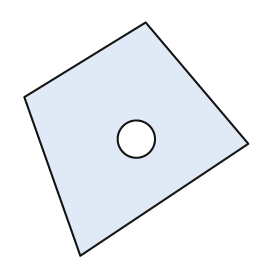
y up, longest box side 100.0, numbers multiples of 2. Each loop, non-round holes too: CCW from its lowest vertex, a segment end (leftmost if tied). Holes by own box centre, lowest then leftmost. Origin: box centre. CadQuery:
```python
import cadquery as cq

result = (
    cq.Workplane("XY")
    .moveTo(-24.0, -50.0)
    .lineTo(48.0, -2.0)
    .lineTo(4.0, 50.0)
    .lineTo(-48.0, 18.0)
    .close()
    .moveTo(0.0, 0.0)
    .circle(8.0)
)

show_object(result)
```